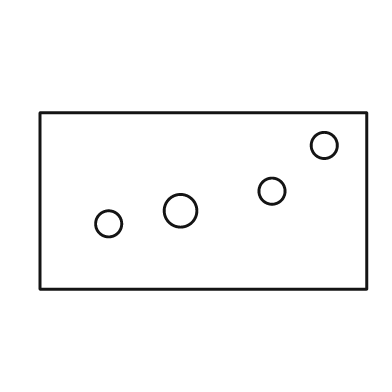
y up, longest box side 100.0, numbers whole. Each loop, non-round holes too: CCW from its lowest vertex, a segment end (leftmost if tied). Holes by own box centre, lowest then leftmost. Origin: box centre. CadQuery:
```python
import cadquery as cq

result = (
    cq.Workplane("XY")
    .moveTo(-50.0, -27.0)
    .lineTo(50.0, -27.0)
    .lineTo(50.0, 27.0)
    .lineTo(-50.0, 27.0)
    .close()
    .moveTo(-29.0, -7.0)
    .circle(4.0)
    .moveTo(-7.0, -3.0)
    .circle(5.0)
    .moveTo(21.0, 3.0)
    .circle(4.0)
    .moveTo(37.0, 17.0)
    .circle(4.0)
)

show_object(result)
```